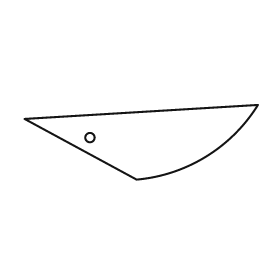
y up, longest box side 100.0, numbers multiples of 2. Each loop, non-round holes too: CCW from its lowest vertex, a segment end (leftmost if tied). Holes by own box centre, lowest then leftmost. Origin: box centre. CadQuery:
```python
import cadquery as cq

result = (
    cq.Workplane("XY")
    .moveTo(-2.0, -16.0)
    .threePointArc((28.0, -6.0), (50.0, 16.0))
    .lineTo(-50.0, 10.0)
    .close()
    .moveTo(-22.0, 2.0)
    .circle(2.0)
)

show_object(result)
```